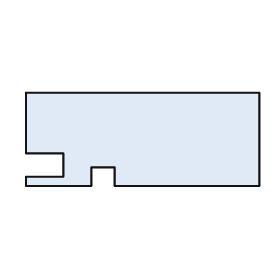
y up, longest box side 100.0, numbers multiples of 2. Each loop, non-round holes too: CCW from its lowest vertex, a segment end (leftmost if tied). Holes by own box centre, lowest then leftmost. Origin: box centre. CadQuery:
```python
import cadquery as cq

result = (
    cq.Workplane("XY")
    .moveTo(-50.0, -20.0)
    .lineTo(-22.0, -20.0)
    .lineTo(-22.0, -12.0)
    .lineTo(-12.0, -12.0)
    .lineTo(-12.0, -20.0)
    .lineTo(50.0, -20.0)
    .lineTo(50.0, 20.0)
    .lineTo(-50.0, 20.0)
    .lineTo(-50.0, -6.0)
    .lineTo(-34.0, -6.0)
    .lineTo(-34.0, -16.0)
    .lineTo(-50.0, -16.0)
    .close()
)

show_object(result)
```